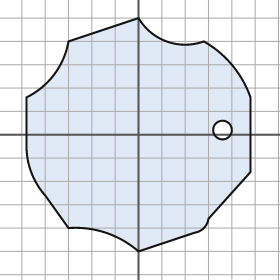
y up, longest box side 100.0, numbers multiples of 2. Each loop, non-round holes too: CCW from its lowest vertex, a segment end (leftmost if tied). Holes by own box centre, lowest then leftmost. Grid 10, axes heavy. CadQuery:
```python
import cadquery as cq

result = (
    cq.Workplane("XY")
    .moveTo(0.0, -50.0)
    .lineTo(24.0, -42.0)
    .threePointArc((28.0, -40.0), (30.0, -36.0))
    .lineTo(48.0, -16.0)
    .lineTo(48.0, 16.0)
    .threePointArc((40.0, 30.0), (28.0, 40.0))
    .threePointArc((12.0, 40.0), (0.0, 50.0))
    .lineTo(-30.0, 40.0)
    .threePointArc((-36.0, 26.0), (-48.0, 16.0))
    .lineTo(-48.0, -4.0)
    .threePointArc((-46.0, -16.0), (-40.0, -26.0))
    .lineTo(-30.0, -40.0)
    .threePointArc((-14.0, -42.0), (0.0, -50.0))
    .close()
    .moveTo(36.0, 2.0)
    .circle(4.0)
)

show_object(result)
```